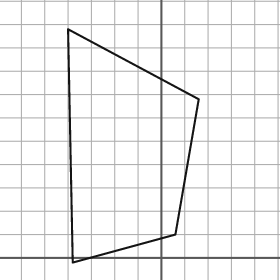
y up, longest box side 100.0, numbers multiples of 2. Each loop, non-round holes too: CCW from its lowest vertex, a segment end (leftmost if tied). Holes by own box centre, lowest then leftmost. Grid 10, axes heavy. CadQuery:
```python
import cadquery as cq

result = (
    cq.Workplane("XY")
    .moveTo(-38.0, -2.0)
    .lineTo(6.0, 10.0)
    .lineTo(16.0, 68.0)
    .lineTo(-40.0, 98.0)
    .close()
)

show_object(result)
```